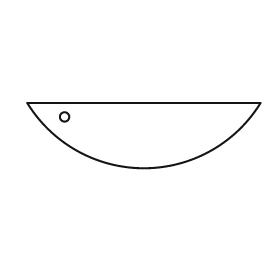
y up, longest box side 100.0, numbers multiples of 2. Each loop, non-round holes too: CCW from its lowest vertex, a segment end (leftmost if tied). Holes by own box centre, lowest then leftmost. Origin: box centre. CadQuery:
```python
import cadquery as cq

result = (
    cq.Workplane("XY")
    .moveTo(-50.0, 14.0)
    .threePointArc((0.0, -14.0), (50.0, 14.0))
    .close()
    .moveTo(-34.0, 8.0)
    .circle(2.0)
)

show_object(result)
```